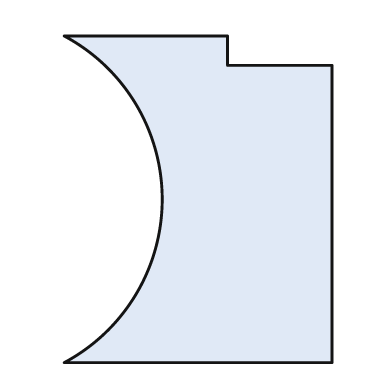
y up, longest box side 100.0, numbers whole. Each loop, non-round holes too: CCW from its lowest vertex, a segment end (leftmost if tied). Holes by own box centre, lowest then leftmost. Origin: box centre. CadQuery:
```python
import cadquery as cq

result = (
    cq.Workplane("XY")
    .moveTo(-41.0, -50.0)
    .lineTo(41.0, -50.0)
    .lineTo(41.0, 41.0)
    .lineTo(9.0, 41.0)
    .lineTo(9.0, 50.0)
    .lineTo(-41.0, 50.0)
    .threePointArc((-11.0, 0.0), (-41.0, -50.0))
    .close()
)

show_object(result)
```